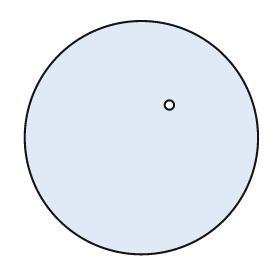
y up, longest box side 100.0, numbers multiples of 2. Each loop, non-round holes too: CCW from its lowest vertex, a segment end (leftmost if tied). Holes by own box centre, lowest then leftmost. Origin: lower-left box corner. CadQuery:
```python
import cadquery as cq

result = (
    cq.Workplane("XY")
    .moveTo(50.0, 50.0)
    .circle(50.0)
    .moveTo(62.0, 64.0)
    .circle(2.0)
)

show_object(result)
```